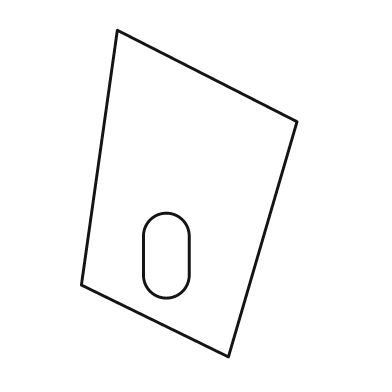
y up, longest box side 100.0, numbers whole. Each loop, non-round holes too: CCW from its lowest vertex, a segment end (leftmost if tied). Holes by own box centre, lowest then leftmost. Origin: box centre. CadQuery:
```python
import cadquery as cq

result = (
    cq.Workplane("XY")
    .moveTo(12.0, -50.0)
    .lineTo(33.0, 22.0)
    .lineTo(-22.0, 50.0)
    .lineTo(-33.0, -28.0)
    .close()
    .moveTo(-14.0, -25.0)
    .threePointArc((-7.0, -32.0), (0.0, -25.0))
    .lineTo(0.0, -13.0)
    .threePointArc((-7.0, -6.0), (-14.0, -13.0))
    .close()
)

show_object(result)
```